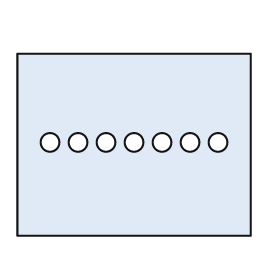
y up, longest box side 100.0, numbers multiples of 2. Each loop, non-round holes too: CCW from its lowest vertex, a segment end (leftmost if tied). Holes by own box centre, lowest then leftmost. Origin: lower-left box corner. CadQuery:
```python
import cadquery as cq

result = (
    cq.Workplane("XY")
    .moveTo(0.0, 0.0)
    .lineTo(100.0, 0.0)
    .lineTo(100.0, 78.0)
    .lineTo(0.0, 78.0)
    .close()
    .moveTo(14.0, 40.0)
    .circle(4.0)
    .moveTo(26.0, 40.0)
    .circle(4.0)
    .moveTo(38.0, 40.0)
    .circle(4.0)
    .moveTo(50.0, 40.0)
    .circle(4.0)
    .moveTo(62.0, 40.0)
    .circle(4.0)
    .moveTo(74.0, 40.0)
    .circle(4.0)
    .moveTo(86.0, 40.0)
    .circle(4.0)
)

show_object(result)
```